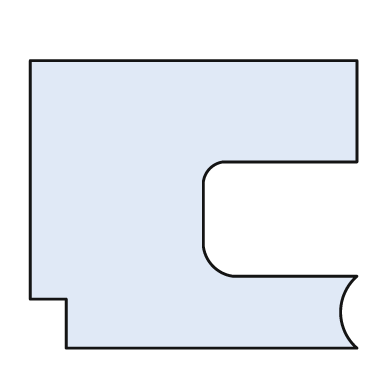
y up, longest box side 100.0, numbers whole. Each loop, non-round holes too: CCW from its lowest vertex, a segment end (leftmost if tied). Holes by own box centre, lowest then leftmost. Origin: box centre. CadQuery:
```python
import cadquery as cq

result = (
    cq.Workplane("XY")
    .moveTo(-39.0, -44.0)
    .lineTo(50.0, -44.0)
    .threePointArc((45.0, -33.0), (50.0, -22.0))
    .lineTo(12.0, -22.0)
    .threePointArc((6.0, -19.0), (3.0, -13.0))
    .lineTo(3.0, 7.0)
    .threePointArc((5.0, 11.0), (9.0, 13.0))
    .lineTo(50.0, 13.0)
    .lineTo(50.0, 44.0)
    .lineTo(-50.0, 44.0)
    .lineTo(-50.0, -29.0)
    .lineTo(-39.0, -29.0)
    .close()
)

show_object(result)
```